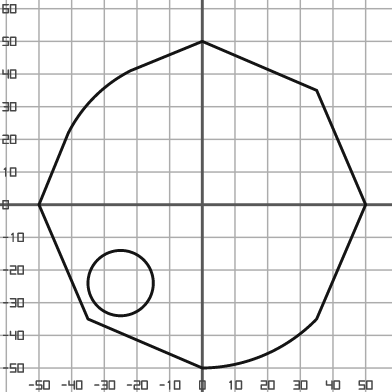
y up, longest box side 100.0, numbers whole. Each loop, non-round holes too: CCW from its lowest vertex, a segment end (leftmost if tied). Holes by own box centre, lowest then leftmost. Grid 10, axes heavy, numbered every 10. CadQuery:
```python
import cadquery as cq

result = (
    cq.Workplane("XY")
    .moveTo(0.0, -50.0)
    .threePointArc((19.0, -46.0), (35.0, -35.0))
    .lineTo(50.0, 0.0)
    .lineTo(35.0, 35.0)
    .lineTo(0.0, 50.0)
    .lineTo(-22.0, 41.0)
    .threePointArc((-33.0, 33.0), (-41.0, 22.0))
    .lineTo(-50.0, 0.0)
    .lineTo(-35.0, -35.0)
    .close()
    .moveTo(-25.0, -24.0)
    .circle(10.0)
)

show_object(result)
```